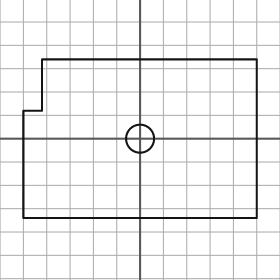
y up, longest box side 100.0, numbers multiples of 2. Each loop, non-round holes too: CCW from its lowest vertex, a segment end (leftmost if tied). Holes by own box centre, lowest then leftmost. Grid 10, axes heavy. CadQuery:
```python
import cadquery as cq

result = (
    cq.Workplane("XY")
    .moveTo(-50.0, -34.0)
    .lineTo(50.0, -34.0)
    .lineTo(50.0, 34.0)
    .lineTo(-42.0, 34.0)
    .lineTo(-42.0, 12.0)
    .lineTo(-50.0, 12.0)
    .close()
    .moveTo(0.0, 0.0)
    .circle(6.0)
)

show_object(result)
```